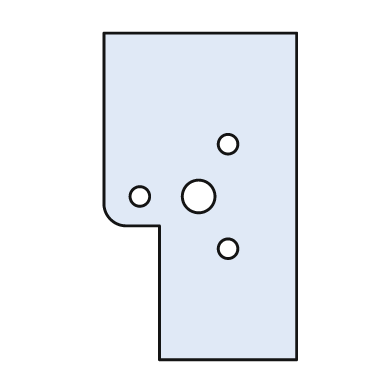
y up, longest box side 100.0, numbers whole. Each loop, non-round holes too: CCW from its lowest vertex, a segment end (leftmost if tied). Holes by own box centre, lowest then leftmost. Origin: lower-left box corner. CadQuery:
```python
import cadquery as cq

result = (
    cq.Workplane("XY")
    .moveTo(17.0, 0.0)
    .lineTo(59.0, 0.0)
    .lineTo(59.0, 100.0)
    .lineTo(0.0, 100.0)
    .lineTo(0.0, 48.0)
    .threePointArc((2.0, 43.0), (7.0, 41.0))
    .lineTo(17.0, 41.0)
    .close()
    .moveTo(38.0, 34.0)
    .circle(3.0)
    .moveTo(11.0, 50.0)
    .circle(3.0)
    .moveTo(29.0, 50.0)
    .circle(5.0)
    .moveTo(38.0, 66.0)
    .circle(3.0)
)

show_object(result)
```